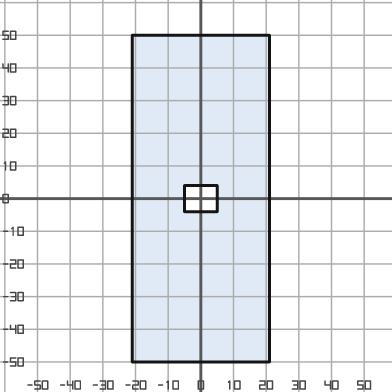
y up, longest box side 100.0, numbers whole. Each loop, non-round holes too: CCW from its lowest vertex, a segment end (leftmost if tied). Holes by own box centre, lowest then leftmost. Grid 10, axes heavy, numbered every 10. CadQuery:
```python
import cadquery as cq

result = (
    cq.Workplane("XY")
    .moveTo(-21.0, -50.0)
    .lineTo(21.0, -50.0)
    .lineTo(21.0, 50.0)
    .lineTo(-21.0, 50.0)
    .close()
    .moveTo(-5.0, -4.0)
    .lineTo(5.0, -4.0)
    .lineTo(5.0, 4.0)
    .lineTo(-5.0, 4.0)
    .close()
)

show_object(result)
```